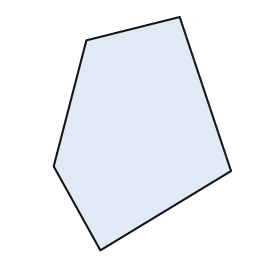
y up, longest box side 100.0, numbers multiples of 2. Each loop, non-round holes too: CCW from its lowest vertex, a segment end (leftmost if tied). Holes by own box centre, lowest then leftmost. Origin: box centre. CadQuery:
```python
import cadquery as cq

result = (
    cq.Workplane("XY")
    .moveTo(-18.0, -50.0)
    .lineTo(38.0, -16.0)
    .lineTo(16.0, 50.0)
    .lineTo(-24.0, 40.0)
    .lineTo(-38.0, -14.0)
    .close()
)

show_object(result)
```